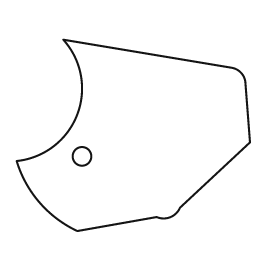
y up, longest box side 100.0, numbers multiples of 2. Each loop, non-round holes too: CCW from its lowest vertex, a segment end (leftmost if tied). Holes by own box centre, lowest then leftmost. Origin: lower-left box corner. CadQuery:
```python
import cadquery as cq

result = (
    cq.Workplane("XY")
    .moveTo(26.0, 0.0)
    .lineTo(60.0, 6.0)
    .threePointArc((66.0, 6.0), (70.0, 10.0))
    .lineTo(100.0, 38.0)
    .lineTo(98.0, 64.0)
    .threePointArc((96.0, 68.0), (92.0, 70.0))
    .lineTo(20.0, 82.0)
    .threePointArc((26.0, 50.0), (0.0, 30.0))
    .threePointArc((10.0, 12.0), (26.0, 0.0))
    .close()
    .moveTo(28.0, 32.0)
    .circle(4.0)
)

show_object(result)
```